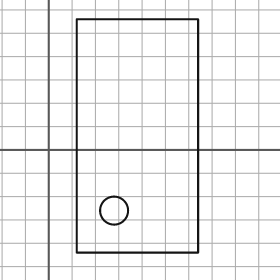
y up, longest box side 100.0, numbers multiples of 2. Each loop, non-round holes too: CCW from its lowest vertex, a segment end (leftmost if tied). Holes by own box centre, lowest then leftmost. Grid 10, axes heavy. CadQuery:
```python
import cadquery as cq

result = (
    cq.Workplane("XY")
    .moveTo(12.0, -44.0)
    .lineTo(64.0, -44.0)
    .lineTo(64.0, 56.0)
    .lineTo(12.0, 56.0)
    .close()
    .moveTo(28.0, -26.0)
    .circle(6.0)
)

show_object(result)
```